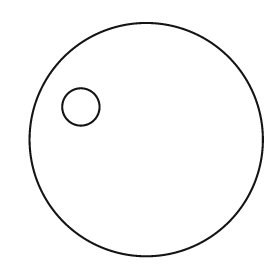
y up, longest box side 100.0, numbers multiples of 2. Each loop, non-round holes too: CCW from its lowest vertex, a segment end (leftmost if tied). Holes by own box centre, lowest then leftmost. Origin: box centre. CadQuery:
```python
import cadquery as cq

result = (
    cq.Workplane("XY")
    .moveTo(0.0, 0.0)
    .circle(50.0)
    .moveTo(-28.0, 14.0)
    .circle(8.0)
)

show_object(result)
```